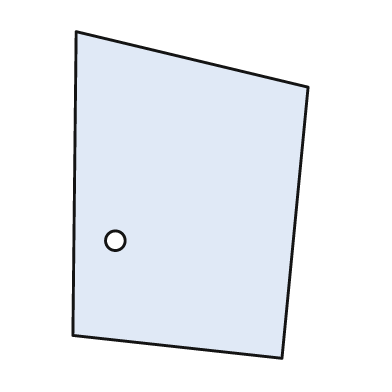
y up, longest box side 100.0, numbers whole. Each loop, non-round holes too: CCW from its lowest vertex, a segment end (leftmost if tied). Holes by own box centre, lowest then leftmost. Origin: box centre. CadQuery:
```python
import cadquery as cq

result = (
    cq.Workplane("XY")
    .moveTo(28.0, -50.0)
    .lineTo(36.0, 33.0)
    .lineTo(-35.0, 50.0)
    .lineTo(-36.0, -43.0)
    .close()
    .moveTo(-23.0, -14.0)
    .circle(3.0)
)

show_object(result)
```